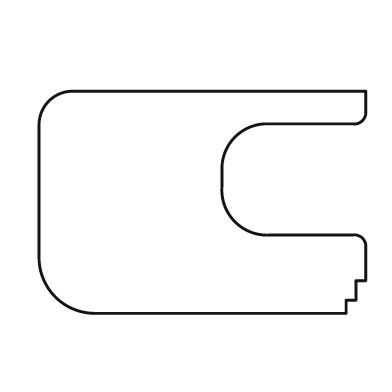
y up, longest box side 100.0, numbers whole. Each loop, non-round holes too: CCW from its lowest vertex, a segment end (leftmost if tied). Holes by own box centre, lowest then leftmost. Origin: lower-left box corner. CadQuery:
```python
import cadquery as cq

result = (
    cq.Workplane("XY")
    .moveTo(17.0, 0.0)
    .lineTo(94.0, 0.0)
    .lineTo(94.0, 4.0)
    .lineTo(97.0, 4.0)
    .lineTo(97.0, 10.0)
    .lineTo(100.0, 10.0)
    .lineTo(100.0, 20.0)
    .threePointArc((99.0, 23.0), (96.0, 24.0))
    .lineTo(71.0, 24.0)
    .threePointArc((60.0, 28.0), (56.0, 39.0))
    .lineTo(56.0, 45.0)
    .threePointArc((60.0, 54.0), (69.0, 58.0))
    .lineTo(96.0, 58.0)
    .threePointArc((99.0, 59.0), (100.0, 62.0))
    .lineTo(100.0, 68.0)
    .lineTo(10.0, 68.0)
    .threePointArc((3.0, 65.0), (0.0, 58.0))
    .lineTo(0.0, 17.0)
    .threePointArc((5.0, 5.0), (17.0, 0.0))
    .close()
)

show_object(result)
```